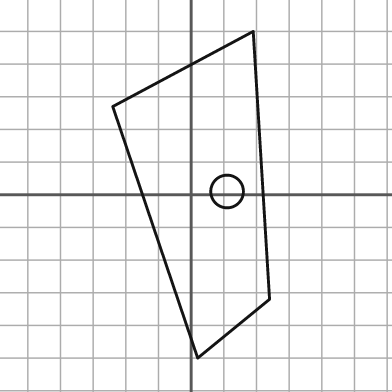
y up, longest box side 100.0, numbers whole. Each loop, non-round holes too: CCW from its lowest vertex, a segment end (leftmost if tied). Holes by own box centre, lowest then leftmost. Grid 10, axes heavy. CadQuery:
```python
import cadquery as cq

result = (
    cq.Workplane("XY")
    .moveTo(2.0, -50.0)
    .lineTo(24.0, -32.0)
    .lineTo(19.0, 50.0)
    .lineTo(-24.0, 27.0)
    .close()
    .moveTo(11.0, 1.0)
    .circle(5.0)
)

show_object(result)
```